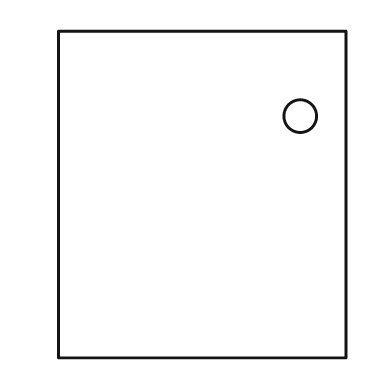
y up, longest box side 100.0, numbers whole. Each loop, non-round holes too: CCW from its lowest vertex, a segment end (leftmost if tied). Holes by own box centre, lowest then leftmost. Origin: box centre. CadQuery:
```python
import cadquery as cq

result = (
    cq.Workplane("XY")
    .moveTo(-44.0, -50.0)
    .lineTo(44.0, -50.0)
    .lineTo(44.0, 50.0)
    .lineTo(-44.0, 50.0)
    .close()
    .moveTo(30.0, 24.0)
    .circle(5.0)
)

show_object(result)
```